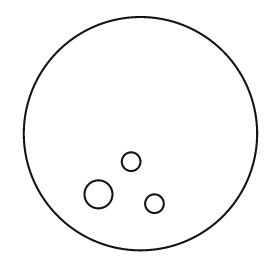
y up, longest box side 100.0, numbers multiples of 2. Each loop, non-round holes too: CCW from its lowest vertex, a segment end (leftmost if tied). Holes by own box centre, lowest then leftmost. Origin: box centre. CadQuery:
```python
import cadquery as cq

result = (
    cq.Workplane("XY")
    .moveTo(0.0, 0.0)
    .circle(50.0)
    .moveTo(6.0, -30.0)
    .circle(4.0)
    .moveTo(-18.0, -26.0)
    .circle(6.0)
    .moveTo(-4.0, -12.0)
    .circle(4.0)
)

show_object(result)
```